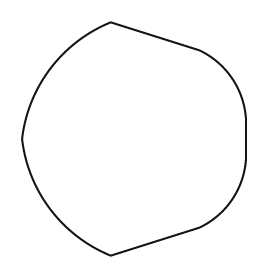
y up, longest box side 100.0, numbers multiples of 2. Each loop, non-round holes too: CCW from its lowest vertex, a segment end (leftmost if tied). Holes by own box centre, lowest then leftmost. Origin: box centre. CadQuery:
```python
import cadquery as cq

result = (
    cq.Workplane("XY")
    .moveTo(-10.0, -50.0)
    .lineTo(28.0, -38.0)
    .threePointArc((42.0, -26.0), (48.0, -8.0))
    .lineTo(48.0, 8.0)
    .threePointArc((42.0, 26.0), (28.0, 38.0))
    .lineTo(-10.0, 50.0)
    .threePointArc((-36.0, 30.0), (-48.0, 0.0))
    .threePointArc((-36.0, -30.0), (-10.0, -50.0))
    .close()
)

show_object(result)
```